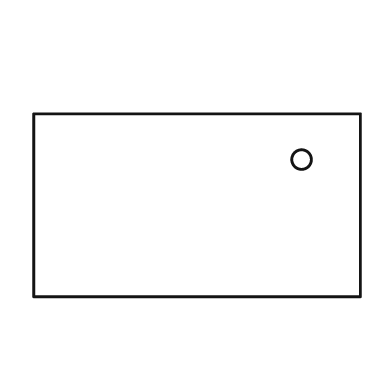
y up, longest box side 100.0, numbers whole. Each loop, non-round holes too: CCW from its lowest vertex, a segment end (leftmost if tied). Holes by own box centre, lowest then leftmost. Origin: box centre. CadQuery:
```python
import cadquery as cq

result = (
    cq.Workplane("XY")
    .moveTo(-50.0, -28.0)
    .lineTo(50.0, -28.0)
    .lineTo(50.0, 28.0)
    .lineTo(-50.0, 28.0)
    .close()
    .moveTo(32.0, 14.0)
    .circle(3.0)
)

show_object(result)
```